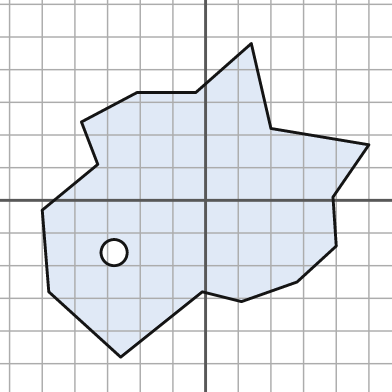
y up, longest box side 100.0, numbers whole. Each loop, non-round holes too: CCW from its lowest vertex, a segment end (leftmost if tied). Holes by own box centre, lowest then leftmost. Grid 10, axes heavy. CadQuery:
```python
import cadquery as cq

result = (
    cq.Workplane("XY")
    .moveTo(-26.0, -48.0)
    .lineTo(-1.0, -28.0)
    .lineTo(11.0, -31.0)
    .lineTo(28.0, -25.0)
    .lineTo(40.0, -14.0)
    .lineTo(39.0, 1.0)
    .lineTo(50.0, 17.0)
    .lineTo(20.0, 22.0)
    .lineTo(14.0, 48.0)
    .lineTo(-3.0, 33.0)
    .lineTo(-21.0, 33.0)
    .lineTo(-38.0, 24.0)
    .lineTo(-33.0, 11.0)
    .lineTo(-50.0, -3.0)
    .lineTo(-48.0, -28.0)
    .close()
    .moveTo(-28.0, -16.0)
    .circle(4.0)
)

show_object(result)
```